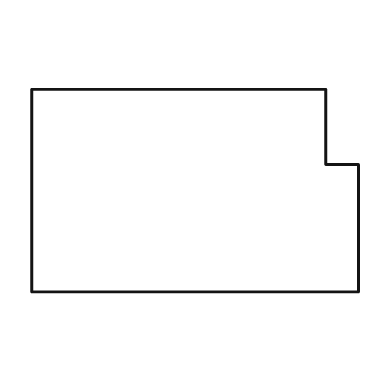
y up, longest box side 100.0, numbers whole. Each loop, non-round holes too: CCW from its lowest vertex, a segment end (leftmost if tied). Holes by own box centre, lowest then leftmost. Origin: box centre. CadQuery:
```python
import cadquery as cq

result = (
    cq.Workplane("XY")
    .moveTo(-50.0, -31.0)
    .lineTo(50.0, -31.0)
    .lineTo(50.0, 8.0)
    .lineTo(40.0, 8.0)
    .lineTo(40.0, 31.0)
    .lineTo(-50.0, 31.0)
    .close()
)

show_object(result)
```